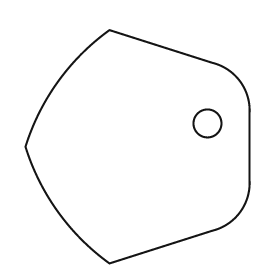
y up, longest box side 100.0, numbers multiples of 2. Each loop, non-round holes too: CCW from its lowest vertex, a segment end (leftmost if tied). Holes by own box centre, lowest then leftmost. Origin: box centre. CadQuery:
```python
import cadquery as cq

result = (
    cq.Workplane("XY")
    .moveTo(-12.0, -50.0)
    .lineTo(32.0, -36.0)
    .threePointArc((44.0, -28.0), (48.0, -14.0))
    .lineTo(48.0, 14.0)
    .threePointArc((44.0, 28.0), (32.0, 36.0))
    .lineTo(-12.0, 50.0)
    .threePointArc((-34.0, 28.0), (-48.0, 0.0))
    .threePointArc((-34.0, -28.0), (-12.0, -50.0))
    .close()
    .moveTo(30.0, 10.0)
    .circle(6.0)
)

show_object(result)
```